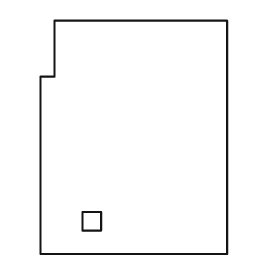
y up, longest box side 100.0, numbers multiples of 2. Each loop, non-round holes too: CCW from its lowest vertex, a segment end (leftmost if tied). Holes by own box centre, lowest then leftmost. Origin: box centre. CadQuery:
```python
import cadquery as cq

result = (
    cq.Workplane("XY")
    .moveTo(-40.0, -50.0)
    .lineTo(40.0, -50.0)
    .lineTo(40.0, 50.0)
    .lineTo(-34.0, 50.0)
    .lineTo(-34.0, 26.0)
    .lineTo(-40.0, 26.0)
    .close()
    .moveTo(-22.0, -40.0)
    .lineTo(-14.0, -40.0)
    .lineTo(-14.0, -32.0)
    .lineTo(-22.0, -32.0)
    .close()
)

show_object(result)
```